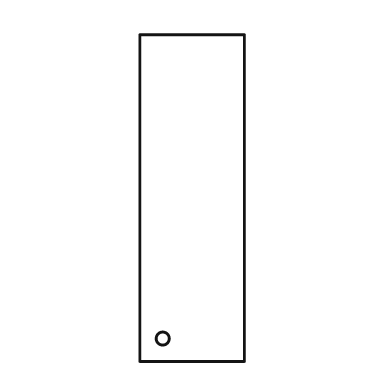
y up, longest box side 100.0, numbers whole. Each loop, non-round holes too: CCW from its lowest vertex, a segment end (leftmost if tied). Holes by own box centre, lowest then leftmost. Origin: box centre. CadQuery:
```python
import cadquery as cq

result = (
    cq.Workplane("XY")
    .moveTo(-16.0, -50.0)
    .lineTo(16.0, -50.0)
    .lineTo(16.0, 50.0)
    .lineTo(-16.0, 50.0)
    .close()
    .moveTo(-9.0, -43.0)
    .circle(2.0)
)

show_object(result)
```